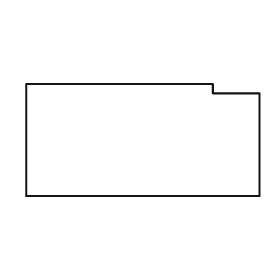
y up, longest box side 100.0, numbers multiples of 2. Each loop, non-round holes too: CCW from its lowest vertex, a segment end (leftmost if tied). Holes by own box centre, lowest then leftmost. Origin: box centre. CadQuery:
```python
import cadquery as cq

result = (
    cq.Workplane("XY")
    .moveTo(-50.0, -24.0)
    .lineTo(50.0, -24.0)
    .lineTo(50.0, 20.0)
    .lineTo(30.0, 20.0)
    .lineTo(30.0, 24.0)
    .lineTo(-50.0, 24.0)
    .close()
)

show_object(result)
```